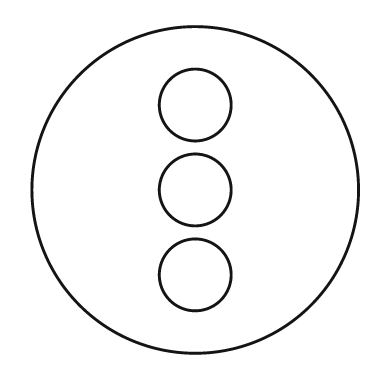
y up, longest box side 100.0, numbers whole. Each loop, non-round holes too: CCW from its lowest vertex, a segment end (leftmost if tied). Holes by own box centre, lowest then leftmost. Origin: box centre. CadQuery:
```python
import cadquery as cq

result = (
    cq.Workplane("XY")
    .moveTo(0.0, 0.0)
    .circle(50.0)
    .moveTo(0.0, -26.0)
    .circle(11.0)
    .moveTo(0.0, 0.0)
    .circle(11.0)
    .moveTo(0.0, 26.0)
    .circle(11.0)
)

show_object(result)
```